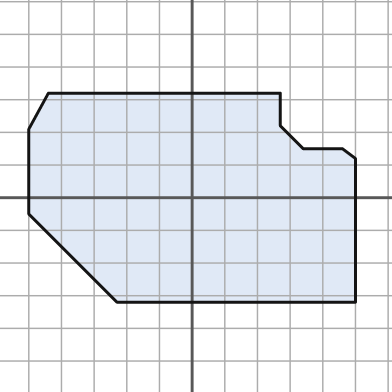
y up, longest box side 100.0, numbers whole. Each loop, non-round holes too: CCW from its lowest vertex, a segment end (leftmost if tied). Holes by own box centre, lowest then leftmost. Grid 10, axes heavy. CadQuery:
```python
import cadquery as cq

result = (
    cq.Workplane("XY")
    .moveTo(-23.0, -32.0)
    .lineTo(50.0, -32.0)
    .lineTo(50.0, 12.0)
    .lineTo(46.0, 15.0)
    .lineTo(34.0, 15.0)
    .lineTo(27.0, 22.0)
    .lineTo(27.0, 32.0)
    .lineTo(-44.0, 32.0)
    .lineTo(-50.0, 21.0)
    .lineTo(-50.0, -5.0)
    .close()
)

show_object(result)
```